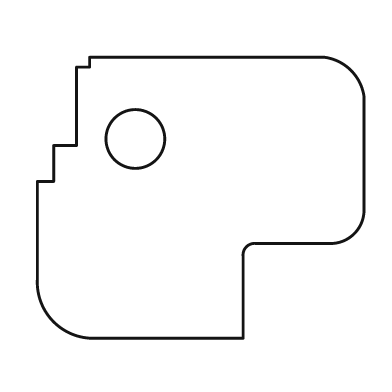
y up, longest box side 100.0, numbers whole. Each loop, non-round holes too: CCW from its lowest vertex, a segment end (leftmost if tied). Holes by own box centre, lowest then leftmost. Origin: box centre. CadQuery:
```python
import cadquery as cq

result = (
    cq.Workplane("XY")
    .moveTo(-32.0, -43.0)
    .lineTo(13.0, -43.0)
    .lineTo(13.0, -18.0)
    .threePointArc((14.0, -15.0), (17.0, -14.0))
    .lineTo(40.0, -14.0)
    .threePointArc((47.0, -11.0), (50.0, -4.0))
    .lineTo(50.0, 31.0)
    .threePointArc((46.0, 39.0), (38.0, 43.0))
    .lineTo(-34.0, 43.0)
    .lineTo(-34.0, 40.0)
    .lineTo(-38.0, 40.0)
    .lineTo(-38.0, 16.0)
    .lineTo(-45.0, 16.0)
    .lineTo(-45.0, 5.0)
    .lineTo(-50.0, 5.0)
    .lineTo(-50.0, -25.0)
    .threePointArc((-45.0, -38.0), (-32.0, -43.0))
    .close()
    .moveTo(-20.0, 18.0)
    .circle(9.0)
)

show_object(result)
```